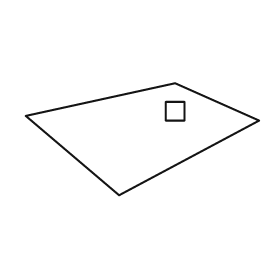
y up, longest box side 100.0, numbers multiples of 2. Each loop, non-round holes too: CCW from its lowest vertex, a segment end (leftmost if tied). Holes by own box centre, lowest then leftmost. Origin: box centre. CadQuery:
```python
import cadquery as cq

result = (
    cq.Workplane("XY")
    .moveTo(-10.0, -24.0)
    .lineTo(50.0, 8.0)
    .lineTo(14.0, 24.0)
    .lineTo(-50.0, 10.0)
    .close()
    .moveTo(10.0, 8.0)
    .lineTo(18.0, 8.0)
    .lineTo(18.0, 16.0)
    .lineTo(10.0, 16.0)
    .close()
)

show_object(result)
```